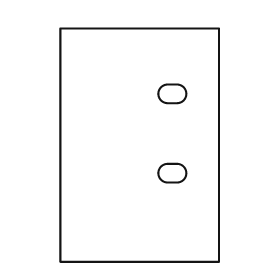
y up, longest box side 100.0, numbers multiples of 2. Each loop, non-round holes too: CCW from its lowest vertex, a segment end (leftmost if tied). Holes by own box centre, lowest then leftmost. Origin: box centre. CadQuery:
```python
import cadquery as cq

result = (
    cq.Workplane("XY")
    .moveTo(-34.0, -50.0)
    .lineTo(34.0, -50.0)
    .lineTo(34.0, 50.0)
    .lineTo(-34.0, 50.0)
    .close()
    .moveTo(12.0, -16.0)
    .lineTo(16.0, -16.0)
    .threePointArc((20.0, -12.0), (16.0, -8.0))
    .lineTo(12.0, -8.0)
    .threePointArc((8.0, -12.0), (12.0, -16.0))
    .close()
    .moveTo(12.0, 18.0)
    .lineTo(16.0, 18.0)
    .threePointArc((20.0, 22.0), (16.0, 26.0))
    .lineTo(12.0, 26.0)
    .threePointArc((8.0, 22.0), (12.0, 18.0))
    .close()
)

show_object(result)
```